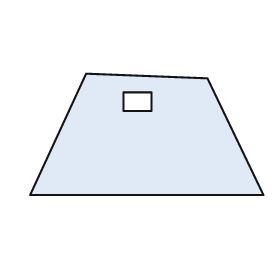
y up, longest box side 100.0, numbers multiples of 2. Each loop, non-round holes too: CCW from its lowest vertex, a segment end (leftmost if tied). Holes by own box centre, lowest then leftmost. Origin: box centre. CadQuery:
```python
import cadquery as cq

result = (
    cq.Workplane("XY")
    .moveTo(-50.0, -26.0)
    .lineTo(50.0, -26.0)
    .lineTo(26.0, 24.0)
    .lineTo(-26.0, 26.0)
    .close()
    .moveTo(-10.0, 10.0)
    .lineTo(2.0, 10.0)
    .lineTo(2.0, 18.0)
    .lineTo(-10.0, 18.0)
    .close()
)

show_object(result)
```